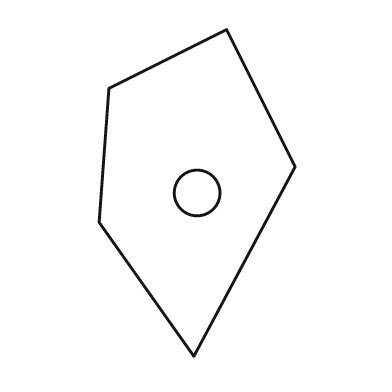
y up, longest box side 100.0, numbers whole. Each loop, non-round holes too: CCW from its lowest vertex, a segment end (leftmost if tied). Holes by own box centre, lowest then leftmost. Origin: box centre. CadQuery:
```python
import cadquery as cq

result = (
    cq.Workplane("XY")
    .moveTo(-1.0, -50.0)
    .lineTo(30.0, 8.0)
    .lineTo(9.0, 50.0)
    .lineTo(-27.0, 32.0)
    .lineTo(-30.0, -9.0)
    .close()
    .moveTo(0.0, 0.0)
    .circle(7.0)
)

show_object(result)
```